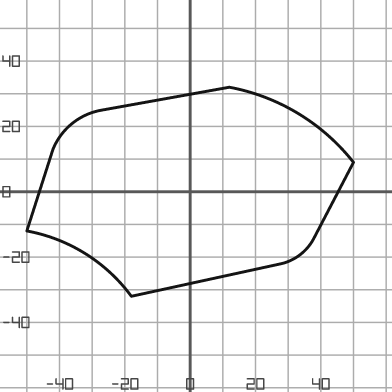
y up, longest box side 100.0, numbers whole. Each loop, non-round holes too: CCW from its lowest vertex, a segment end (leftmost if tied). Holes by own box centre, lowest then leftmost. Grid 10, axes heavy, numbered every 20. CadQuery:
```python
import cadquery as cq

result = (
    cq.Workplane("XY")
    .moveTo(-18.0, -32.0)
    .lineTo(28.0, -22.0)
    .threePointArc((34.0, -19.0), (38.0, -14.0))
    .lineTo(50.0, 9.0)
    .threePointArc((33.0, 24.0), (12.0, 32.0))
    .lineTo(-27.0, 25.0)
    .threePointArc((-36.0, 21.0), (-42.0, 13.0))
    .lineTo(-50.0, -12.0)
    .threePointArc((-32.0, -19.0), (-18.0, -32.0))
    .close()
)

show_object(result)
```